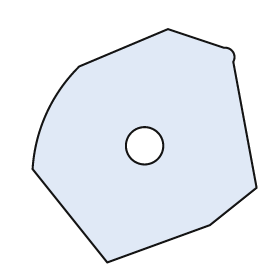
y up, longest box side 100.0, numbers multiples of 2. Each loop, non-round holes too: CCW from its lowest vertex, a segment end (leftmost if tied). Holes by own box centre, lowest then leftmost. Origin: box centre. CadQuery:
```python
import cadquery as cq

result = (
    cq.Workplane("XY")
    .moveTo(-16.0, -50.0)
    .lineTo(28.0, -34.0)
    .lineTo(48.0, -18.0)
    .lineTo(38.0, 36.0)
    .threePointArc((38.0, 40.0), (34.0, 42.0))
    .lineTo(10.0, 50.0)
    .lineTo(-28.0, 34.0)
    .threePointArc((-42.0, 14.0), (-48.0, -10.0))
    .close()
    .moveTo(0.0, 0.0)
    .circle(8.0)
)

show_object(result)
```